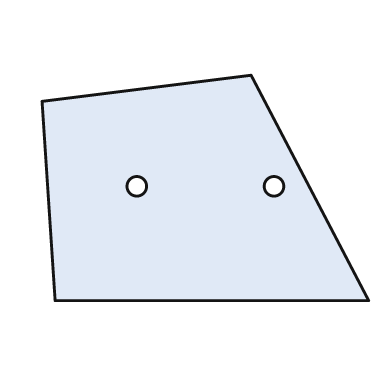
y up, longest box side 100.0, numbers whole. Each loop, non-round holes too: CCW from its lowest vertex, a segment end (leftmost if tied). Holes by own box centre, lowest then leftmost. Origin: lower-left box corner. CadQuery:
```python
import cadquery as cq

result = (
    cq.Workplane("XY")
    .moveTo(4.0, 0.0)
    .lineTo(100.0, 0.0)
    .lineTo(64.0, 69.0)
    .lineTo(0.0, 61.0)
    .close()
    .moveTo(29.0, 35.0)
    .circle(3.0)
    .moveTo(71.0, 35.0)
    .circle(3.0)
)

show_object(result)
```